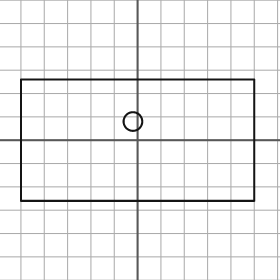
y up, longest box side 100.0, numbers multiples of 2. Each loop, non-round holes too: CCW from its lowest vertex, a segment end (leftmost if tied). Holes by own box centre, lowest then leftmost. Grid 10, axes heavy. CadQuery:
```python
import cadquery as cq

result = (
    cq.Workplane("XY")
    .moveTo(-50.0, -26.0)
    .lineTo(50.0, -26.0)
    .lineTo(50.0, 26.0)
    .lineTo(-50.0, 26.0)
    .close()
    .moveTo(-2.0, 8.0)
    .circle(4.0)
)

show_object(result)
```